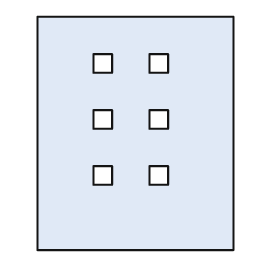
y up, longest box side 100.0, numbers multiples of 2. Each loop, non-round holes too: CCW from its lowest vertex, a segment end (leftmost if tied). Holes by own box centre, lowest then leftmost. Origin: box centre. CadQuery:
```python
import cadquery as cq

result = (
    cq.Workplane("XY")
    .moveTo(-42.0, -50.0)
    .lineTo(42.0, -50.0)
    .lineTo(42.0, 50.0)
    .lineTo(-42.0, 50.0)
    .close()
    .moveTo(-18.0, -22.0)
    .lineTo(-10.0, -22.0)
    .lineTo(-10.0, -14.0)
    .lineTo(-18.0, -14.0)
    .close()
    .moveTo(6.0, -22.0)
    .lineTo(14.0, -22.0)
    .lineTo(14.0, -14.0)
    .lineTo(6.0, -14.0)
    .close()
    .moveTo(-18.0, 2.0)
    .lineTo(-10.0, 2.0)
    .lineTo(-10.0, 10.0)
    .lineTo(-18.0, 10.0)
    .close()
    .moveTo(6.0, 2.0)
    .lineTo(14.0, 2.0)
    .lineTo(14.0, 10.0)
    .lineTo(6.0, 10.0)
    .close()
    .moveTo(-18.0, 26.0)
    .lineTo(-10.0, 26.0)
    .lineTo(-10.0, 34.0)
    .lineTo(-18.0, 34.0)
    .close()
    .moveTo(6.0, 26.0)
    .lineTo(14.0, 26.0)
    .lineTo(14.0, 34.0)
    .lineTo(6.0, 34.0)
    .close()
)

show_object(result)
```